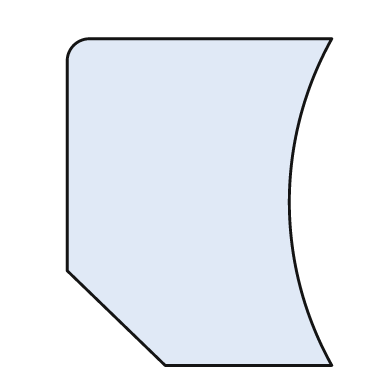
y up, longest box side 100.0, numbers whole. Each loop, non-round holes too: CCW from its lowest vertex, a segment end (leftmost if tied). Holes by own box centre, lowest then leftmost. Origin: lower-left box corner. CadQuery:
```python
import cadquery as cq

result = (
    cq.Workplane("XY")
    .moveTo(30.0, 0.0)
    .lineTo(81.0, 0.0)
    .threePointArc((68.0, 50.0), (81.0, 100.0))
    .lineTo(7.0, 100.0)
    .threePointArc((2.0, 98.0), (0.0, 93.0))
    .lineTo(0.0, 29.0)
    .close()
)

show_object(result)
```